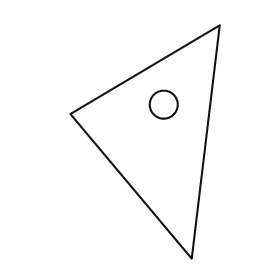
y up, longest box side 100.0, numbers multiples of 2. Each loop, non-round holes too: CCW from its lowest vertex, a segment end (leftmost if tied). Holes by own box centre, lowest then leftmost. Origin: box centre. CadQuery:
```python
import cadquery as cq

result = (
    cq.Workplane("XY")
    .moveTo(20.0, -50.0)
    .lineTo(32.0, 50.0)
    .lineTo(-32.0, 12.0)
    .close()
    .moveTo(8.0, 16.0)
    .circle(6.0)
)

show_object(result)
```